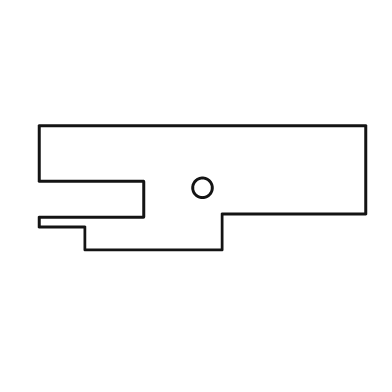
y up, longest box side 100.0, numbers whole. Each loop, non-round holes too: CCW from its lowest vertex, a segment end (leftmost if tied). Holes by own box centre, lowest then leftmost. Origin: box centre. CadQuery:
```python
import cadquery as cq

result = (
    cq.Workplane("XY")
    .moveTo(-36.0, -19.0)
    .lineTo(6.0, -19.0)
    .lineTo(6.0, -8.0)
    .lineTo(50.0, -8.0)
    .lineTo(50.0, 19.0)
    .lineTo(-50.0, 19.0)
    .lineTo(-50.0, 2.0)
    .lineTo(-18.0, 2.0)
    .lineTo(-18.0, -9.0)
    .lineTo(-50.0, -9.0)
    .lineTo(-50.0, -12.0)
    .lineTo(-36.0, -12.0)
    .close()
    .moveTo(0.0, 0.0)
    .circle(3.0)
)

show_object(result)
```